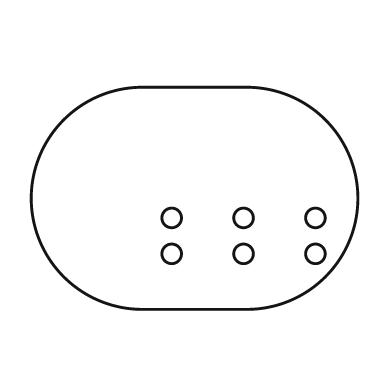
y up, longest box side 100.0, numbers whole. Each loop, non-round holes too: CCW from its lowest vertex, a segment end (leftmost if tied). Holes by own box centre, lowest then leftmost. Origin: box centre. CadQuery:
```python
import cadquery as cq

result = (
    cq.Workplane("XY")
    .moveTo(-16.0, -34.0)
    .lineTo(16.0, -34.0)
    .threePointArc((50.0, 0.0), (16.0, 34.0))
    .lineTo(-16.0, 34.0)
    .threePointArc((-50.0, 0.0), (-16.0, -34.0))
    .close()
    .moveTo(-7.0, -17.0)
    .circle(3.0)
    .moveTo(15.0, -17.0)
    .circle(3.0)
    .moveTo(37.0, -17.0)
    .circle(3.0)
    .moveTo(-7.0, -6.0)
    .circle(3.0)
    .moveTo(15.0, -6.0)
    .circle(3.0)
    .moveTo(37.0, -6.0)
    .circle(3.0)
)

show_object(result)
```